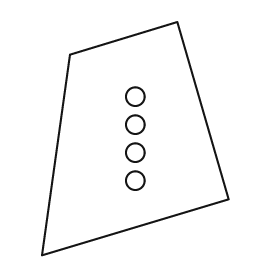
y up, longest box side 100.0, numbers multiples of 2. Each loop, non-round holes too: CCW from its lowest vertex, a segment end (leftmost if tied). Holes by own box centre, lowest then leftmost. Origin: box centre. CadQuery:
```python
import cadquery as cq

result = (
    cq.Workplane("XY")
    .moveTo(-40.0, -50.0)
    .lineTo(40.0, -26.0)
    .lineTo(18.0, 50.0)
    .lineTo(-28.0, 36.0)
    .close()
    .moveTo(0.0, -18.0)
    .circle(4.0)
    .moveTo(0.0, -6.0)
    .circle(4.0)
    .moveTo(0.0, 6.0)
    .circle(4.0)
    .moveTo(0.0, 18.0)
    .circle(4.0)
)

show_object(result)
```